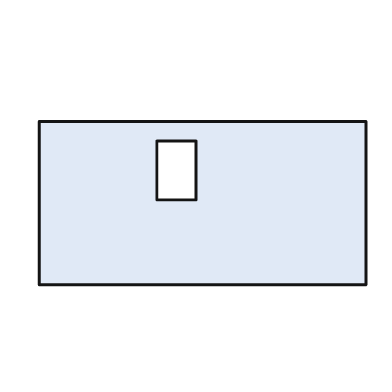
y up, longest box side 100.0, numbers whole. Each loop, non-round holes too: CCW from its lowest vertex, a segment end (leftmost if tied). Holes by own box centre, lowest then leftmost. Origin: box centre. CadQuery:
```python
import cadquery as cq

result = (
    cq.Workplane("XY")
    .moveTo(-50.0, -25.0)
    .lineTo(50.0, -25.0)
    .lineTo(50.0, 25.0)
    .lineTo(-50.0, 25.0)
    .close()
    .moveTo(-14.0, 1.0)
    .lineTo(-2.0, 1.0)
    .lineTo(-2.0, 19.0)
    .lineTo(-14.0, 19.0)
    .close()
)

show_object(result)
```